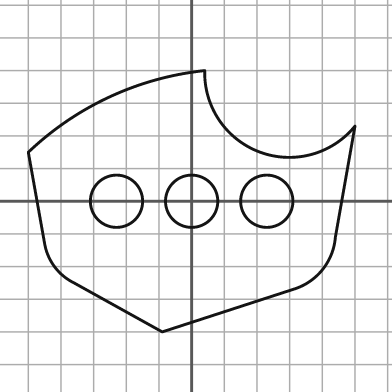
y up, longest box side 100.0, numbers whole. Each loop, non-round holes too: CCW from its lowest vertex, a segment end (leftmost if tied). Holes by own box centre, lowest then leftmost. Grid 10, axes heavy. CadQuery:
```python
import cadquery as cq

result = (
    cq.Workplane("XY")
    .moveTo(-9.0, -40.0)
    .lineTo(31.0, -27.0)
    .threePointArc((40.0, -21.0), (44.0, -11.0))
    .lineTo(50.0, 23.0)
    .threePointArc((21.0, 15.0), (4.0, 40.0))
    .threePointArc((-25.0, 32.0), (-50.0, 15.0))
    .lineTo(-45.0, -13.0)
    .threePointArc((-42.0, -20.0), (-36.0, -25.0))
    .close()
    .moveTo(-23.0, 0.0)
    .circle(8.0)
    .moveTo(0.0, 0.0)
    .circle(8.0)
    .moveTo(23.0, 0.0)
    .circle(8.0)
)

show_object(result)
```